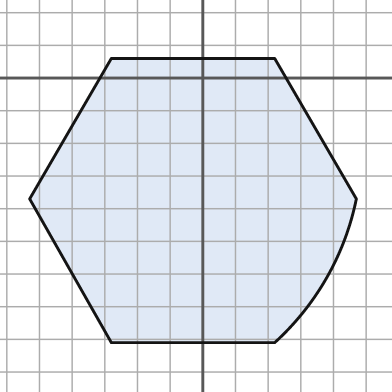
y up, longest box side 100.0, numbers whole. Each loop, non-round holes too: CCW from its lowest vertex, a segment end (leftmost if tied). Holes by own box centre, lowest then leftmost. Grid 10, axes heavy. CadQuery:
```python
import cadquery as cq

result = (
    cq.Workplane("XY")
    .moveTo(-28.0, -81.0)
    .lineTo(22.0, -81.0)
    .threePointArc((38.0, -61.0), (47.0, -37.0))
    .lineTo(22.0, 6.0)
    .lineTo(-28.0, 6.0)
    .lineTo(-53.0, -37.0)
    .close()
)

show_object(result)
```